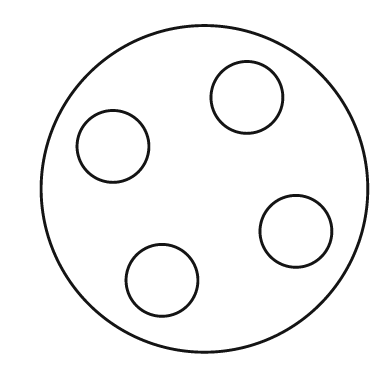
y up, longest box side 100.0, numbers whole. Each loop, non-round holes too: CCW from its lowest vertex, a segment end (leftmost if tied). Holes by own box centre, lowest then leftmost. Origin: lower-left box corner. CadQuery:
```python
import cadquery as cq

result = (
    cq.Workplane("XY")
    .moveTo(50.0, 50.0)
    .circle(50.0)
    .moveTo(37.0, 22.0)
    .circle(11.0)
    .moveTo(78.0, 37.0)
    .circle(11.0)
    .moveTo(22.0, 63.0)
    .circle(11.0)
    .moveTo(63.0, 78.0)
    .circle(11.0)
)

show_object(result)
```